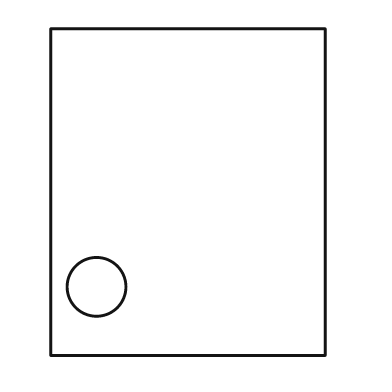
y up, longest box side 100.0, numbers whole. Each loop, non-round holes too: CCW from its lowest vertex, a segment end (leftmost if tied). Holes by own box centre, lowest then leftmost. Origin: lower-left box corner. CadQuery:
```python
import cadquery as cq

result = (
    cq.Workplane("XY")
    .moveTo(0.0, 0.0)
    .lineTo(84.0, 0.0)
    .lineTo(84.0, 100.0)
    .lineTo(0.0, 100.0)
    .close()
    .moveTo(14.0, 21.0)
    .circle(9.0)
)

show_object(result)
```